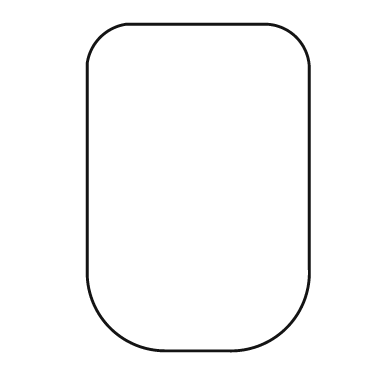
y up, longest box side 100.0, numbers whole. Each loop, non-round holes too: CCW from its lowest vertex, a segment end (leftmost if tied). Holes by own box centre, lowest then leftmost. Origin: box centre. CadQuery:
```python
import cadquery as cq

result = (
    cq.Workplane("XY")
    .moveTo(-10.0, -50.0)
    .lineTo(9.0, -50.0)
    .threePointArc((27.0, -43.0), (34.0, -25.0))
    .lineTo(34.0, 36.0)
    .threePointArc((30.0, 46.0), (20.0, 50.0))
    .lineTo(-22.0, 50.0)
    .threePointArc((-30.0, 46.0), (-34.0, 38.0))
    .lineTo(-34.0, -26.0)
    .threePointArc((-27.0, -43.0), (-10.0, -50.0))
    .close()
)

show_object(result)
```